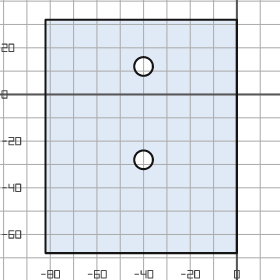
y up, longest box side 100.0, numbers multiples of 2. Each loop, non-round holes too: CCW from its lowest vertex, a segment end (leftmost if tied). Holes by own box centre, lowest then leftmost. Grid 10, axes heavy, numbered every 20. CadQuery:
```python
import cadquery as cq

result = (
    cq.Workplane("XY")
    .moveTo(-82.0, -68.0)
    .lineTo(0.0, -68.0)
    .lineTo(0.0, 32.0)
    .lineTo(-82.0, 32.0)
    .close()
    .moveTo(-40.0, -28.0)
    .circle(4.0)
    .moveTo(-40.0, 12.0)
    .circle(4.0)
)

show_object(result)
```